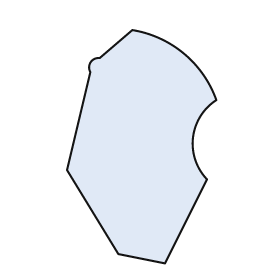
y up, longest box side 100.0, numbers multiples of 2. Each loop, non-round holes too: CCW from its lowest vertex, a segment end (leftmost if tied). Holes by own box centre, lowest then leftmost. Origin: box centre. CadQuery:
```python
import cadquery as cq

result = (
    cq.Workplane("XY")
    .moveTo(10.0, -50.0)
    .lineTo(28.0, -14.0)
    .threePointArc((22.0, 4.0), (32.0, 20.0))
    .threePointArc((18.0, 40.0), (-4.0, 50.0))
    .lineTo(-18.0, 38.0)
    .threePointArc((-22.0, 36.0), (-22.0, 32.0))
    .lineTo(-32.0, -10.0)
    .lineTo(-10.0, -46.0)
    .close()
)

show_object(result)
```